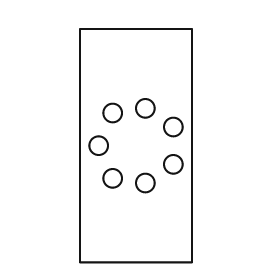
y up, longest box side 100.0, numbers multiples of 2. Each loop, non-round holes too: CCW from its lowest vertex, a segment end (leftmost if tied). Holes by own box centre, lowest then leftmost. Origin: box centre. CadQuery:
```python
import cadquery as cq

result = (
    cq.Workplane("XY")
    .moveTo(-24.0, -50.0)
    .lineTo(24.0, -50.0)
    .lineTo(24.0, 50.0)
    .lineTo(-24.0, 50.0)
    .close()
    .moveTo(4.0, -16.0)
    .circle(4.0)
    .moveTo(-10.0, -14.0)
    .circle(4.0)
    .moveTo(16.0, -8.0)
    .circle(4.0)
    .moveTo(-16.0, 0.0)
    .circle(4.0)
    .moveTo(16.0, 8.0)
    .circle(4.0)
    .moveTo(-10.0, 14.0)
    .circle(4.0)
    .moveTo(4.0, 16.0)
    .circle(4.0)
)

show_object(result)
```